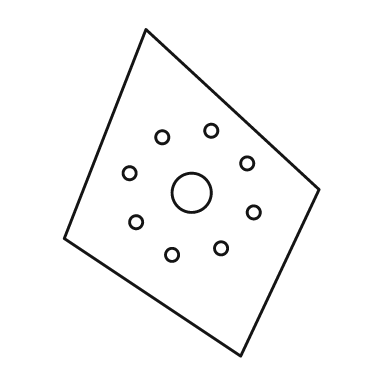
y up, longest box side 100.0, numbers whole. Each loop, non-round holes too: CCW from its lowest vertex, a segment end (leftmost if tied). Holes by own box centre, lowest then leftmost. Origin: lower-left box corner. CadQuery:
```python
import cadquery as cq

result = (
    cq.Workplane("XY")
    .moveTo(54.0, 0.0)
    .lineTo(78.0, 51.0)
    .lineTo(25.0, 100.0)
    .lineTo(0.0, 36.0)
    .close()
    .moveTo(33.0, 31.0)
    .circle(2.0)
    .moveTo(48.0, 33.0)
    .circle(2.0)
    .moveTo(22.0, 41.0)
    .circle(2.0)
    .moveTo(58.0, 44.0)
    .circle(2.0)
    .moveTo(39.0, 50.0)
    .circle(6.0)
    .moveTo(20.0, 56.0)
    .circle(2.0)
    .moveTo(56.0, 59.0)
    .circle(2.0)
    .moveTo(30.0, 67.0)
    .circle(2.0)
    .moveTo(45.0, 69.0)
    .circle(2.0)
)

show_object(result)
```